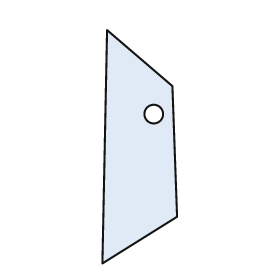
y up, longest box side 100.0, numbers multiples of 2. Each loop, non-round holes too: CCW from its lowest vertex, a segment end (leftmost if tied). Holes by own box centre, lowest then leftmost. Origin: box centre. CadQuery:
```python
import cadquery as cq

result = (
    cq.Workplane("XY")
    .moveTo(-16.0, -50.0)
    .lineTo(16.0, -30.0)
    .lineTo(14.0, 26.0)
    .lineTo(-14.0, 50.0)
    .close()
    .moveTo(6.0, 14.0)
    .circle(4.0)
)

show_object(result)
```